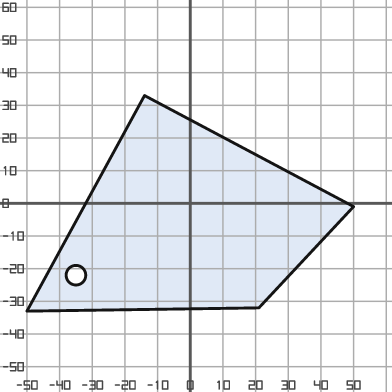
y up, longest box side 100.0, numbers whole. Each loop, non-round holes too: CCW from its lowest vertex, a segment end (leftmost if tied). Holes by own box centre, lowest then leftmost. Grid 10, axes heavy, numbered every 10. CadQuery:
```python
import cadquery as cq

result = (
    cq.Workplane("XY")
    .moveTo(-50.0, -33.0)
    .lineTo(21.0, -32.0)
    .lineTo(50.0, -1.0)
    .lineTo(-14.0, 33.0)
    .close()
    .moveTo(-35.0, -22.0)
    .circle(3.0)
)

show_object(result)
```